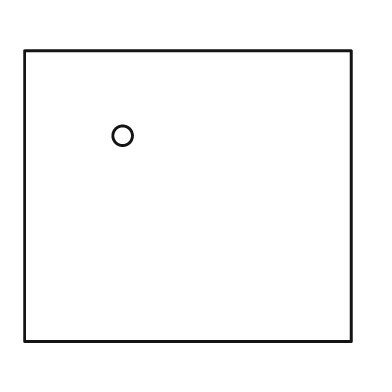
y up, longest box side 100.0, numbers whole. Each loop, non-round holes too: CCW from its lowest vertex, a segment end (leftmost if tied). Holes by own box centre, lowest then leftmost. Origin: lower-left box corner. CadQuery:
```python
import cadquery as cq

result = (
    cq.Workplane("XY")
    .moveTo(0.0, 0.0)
    .lineTo(100.0, 0.0)
    .lineTo(100.0, 89.0)
    .lineTo(0.0, 89.0)
    .close()
    .moveTo(30.0, 63.0)
    .circle(3.0)
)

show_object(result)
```